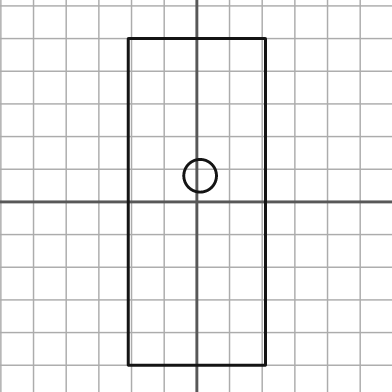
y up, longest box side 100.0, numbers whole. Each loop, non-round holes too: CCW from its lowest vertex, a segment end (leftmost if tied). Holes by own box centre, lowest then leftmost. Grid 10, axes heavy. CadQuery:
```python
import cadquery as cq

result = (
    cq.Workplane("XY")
    .moveTo(-21.0, -50.0)
    .lineTo(21.0, -50.0)
    .lineTo(21.0, 50.0)
    .lineTo(-21.0, 50.0)
    .close()
    .moveTo(1.0, 8.0)
    .circle(5.0)
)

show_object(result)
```